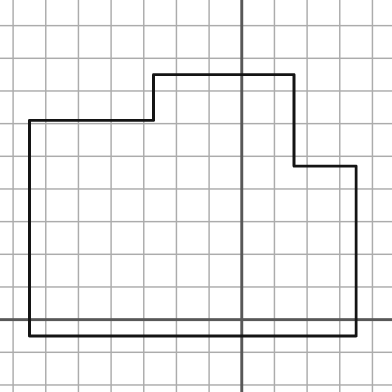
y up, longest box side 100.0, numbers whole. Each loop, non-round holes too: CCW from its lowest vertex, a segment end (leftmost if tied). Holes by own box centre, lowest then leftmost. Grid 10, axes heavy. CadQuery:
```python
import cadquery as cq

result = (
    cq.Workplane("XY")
    .moveTo(-65.0, -5.0)
    .lineTo(35.0, -5.0)
    .lineTo(35.0, 47.0)
    .lineTo(16.0, 47.0)
    .lineTo(16.0, 75.0)
    .lineTo(-27.0, 75.0)
    .lineTo(-27.0, 61.0)
    .lineTo(-65.0, 61.0)
    .close()
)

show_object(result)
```